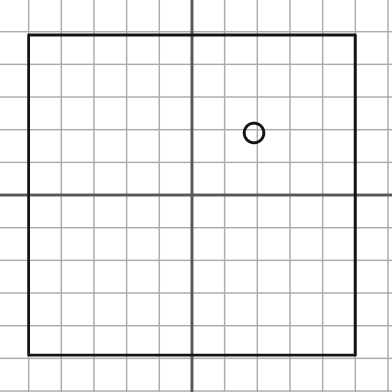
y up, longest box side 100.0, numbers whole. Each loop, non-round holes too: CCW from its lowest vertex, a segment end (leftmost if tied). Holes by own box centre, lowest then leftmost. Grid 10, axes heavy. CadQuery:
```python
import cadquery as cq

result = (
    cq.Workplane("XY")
    .moveTo(-50.0, -49.0)
    .lineTo(50.0, -49.0)
    .lineTo(50.0, 49.0)
    .lineTo(-50.0, 49.0)
    .close()
    .moveTo(19.0, 19.0)
    .circle(3.0)
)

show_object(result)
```